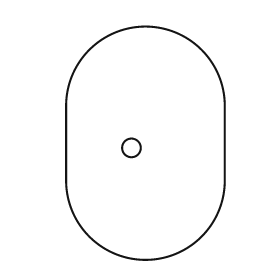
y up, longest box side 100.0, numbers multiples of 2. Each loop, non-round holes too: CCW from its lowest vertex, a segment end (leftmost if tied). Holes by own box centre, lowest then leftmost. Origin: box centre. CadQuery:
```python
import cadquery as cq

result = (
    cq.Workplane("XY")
    .moveTo(-34.0, -16.0)
    .threePointArc((0.0, -50.0), (34.0, -16.0))
    .lineTo(34.0, 16.0)
    .threePointArc((0.0, 50.0), (-34.0, 16.0))
    .close()
    .moveTo(-6.0, -2.0)
    .circle(4.0)
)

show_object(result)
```